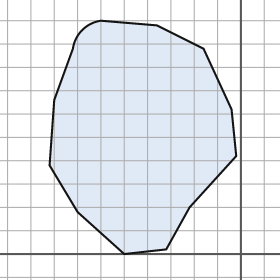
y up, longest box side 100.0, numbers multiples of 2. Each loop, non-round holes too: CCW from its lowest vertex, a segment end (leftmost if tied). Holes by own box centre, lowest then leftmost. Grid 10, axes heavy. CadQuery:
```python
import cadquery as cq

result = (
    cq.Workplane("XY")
    .moveTo(-50.0, 0.0)
    .lineTo(-32.0, 2.0)
    .lineTo(-22.0, 20.0)
    .lineTo(-2.0, 42.0)
    .lineTo(-4.0, 62.0)
    .lineTo(-16.0, 88.0)
    .lineTo(-36.0, 98.0)
    .lineTo(-60.0, 100.0)
    .threePointArc((-68.0, 96.0), (-72.0, 88.0))
    .lineTo(-80.0, 66.0)
    .lineTo(-82.0, 38.0)
    .lineTo(-70.0, 18.0)
    .close()
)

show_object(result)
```